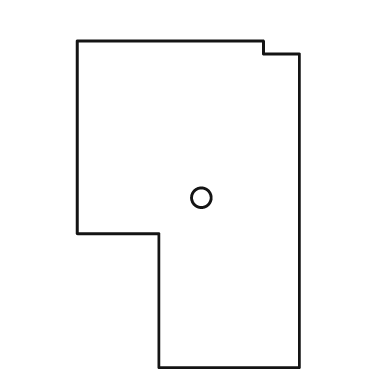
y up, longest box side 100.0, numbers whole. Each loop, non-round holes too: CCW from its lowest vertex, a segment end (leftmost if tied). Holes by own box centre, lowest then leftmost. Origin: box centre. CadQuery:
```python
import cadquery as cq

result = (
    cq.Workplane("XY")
    .moveTo(-9.0, -50.0)
    .lineTo(34.0, -50.0)
    .lineTo(34.0, 46.0)
    .lineTo(23.0, 46.0)
    .lineTo(23.0, 50.0)
    .lineTo(-34.0, 50.0)
    .lineTo(-34.0, -9.0)
    .lineTo(-9.0, -9.0)
    .close()
    .moveTo(4.0, 2.0)
    .circle(3.0)
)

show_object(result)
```